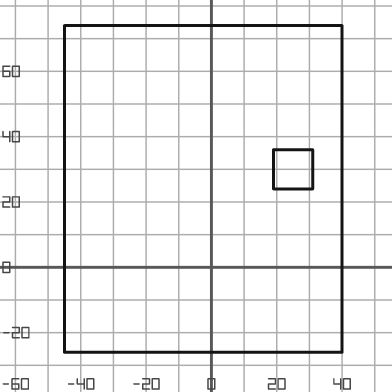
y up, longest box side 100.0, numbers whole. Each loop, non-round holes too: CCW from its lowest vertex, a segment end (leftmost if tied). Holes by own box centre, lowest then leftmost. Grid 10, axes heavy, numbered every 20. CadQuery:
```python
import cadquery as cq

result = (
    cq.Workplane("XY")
    .moveTo(-45.0, -26.0)
    .lineTo(40.0, -26.0)
    .lineTo(40.0, 74.0)
    .lineTo(-45.0, 74.0)
    .close()
    .moveTo(19.0, 24.0)
    .lineTo(31.0, 24.0)
    .lineTo(31.0, 36.0)
    .lineTo(19.0, 36.0)
    .close()
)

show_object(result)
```